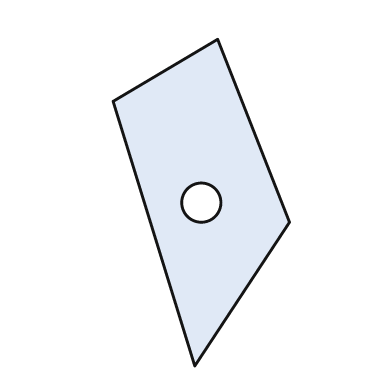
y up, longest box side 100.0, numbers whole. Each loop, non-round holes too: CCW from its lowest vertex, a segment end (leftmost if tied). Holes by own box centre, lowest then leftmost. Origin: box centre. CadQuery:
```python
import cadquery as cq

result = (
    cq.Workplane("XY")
    .moveTo(-2.0, -50.0)
    .lineTo(27.0, -6.0)
    .lineTo(5.0, 50.0)
    .lineTo(-27.0, 31.0)
    .close()
    .moveTo(0.0, 0.0)
    .circle(6.0)
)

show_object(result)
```